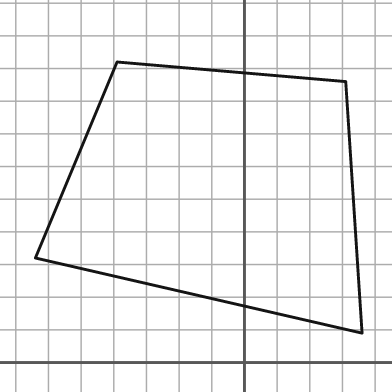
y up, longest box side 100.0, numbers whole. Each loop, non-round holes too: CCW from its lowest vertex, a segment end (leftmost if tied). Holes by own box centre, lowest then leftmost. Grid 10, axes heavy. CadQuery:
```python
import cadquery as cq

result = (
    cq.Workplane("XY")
    .moveTo(36.0, 9.0)
    .lineTo(31.0, 86.0)
    .lineTo(-39.0, 92.0)
    .lineTo(-64.0, 32.0)
    .close()
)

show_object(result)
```